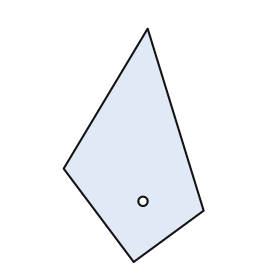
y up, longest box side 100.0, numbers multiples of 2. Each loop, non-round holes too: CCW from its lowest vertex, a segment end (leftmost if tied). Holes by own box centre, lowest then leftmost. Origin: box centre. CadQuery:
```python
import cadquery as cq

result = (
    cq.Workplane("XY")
    .moveTo(0.0, -50.0)
    .lineTo(30.0, -28.0)
    .lineTo(6.0, 50.0)
    .lineTo(-30.0, -10.0)
    .close()
    .moveTo(4.0, -24.0)
    .circle(2.0)
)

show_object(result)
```